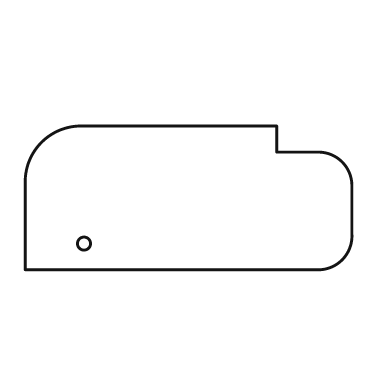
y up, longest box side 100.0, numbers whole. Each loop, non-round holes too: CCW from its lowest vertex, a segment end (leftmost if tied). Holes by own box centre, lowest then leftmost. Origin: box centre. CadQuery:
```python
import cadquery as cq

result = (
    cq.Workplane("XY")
    .moveTo(-50.0, -22.0)
    .lineTo(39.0, -22.0)
    .threePointArc((47.0, -19.0), (50.0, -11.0))
    .lineTo(50.0, 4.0)
    .threePointArc((47.0, 11.0), (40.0, 14.0))
    .lineTo(27.0, 14.0)
    .lineTo(27.0, 22.0)
    .lineTo(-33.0, 22.0)
    .threePointArc((-45.0, 17.0), (-50.0, 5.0))
    .close()
    .moveTo(-32.0, -14.0)
    .circle(2.0)
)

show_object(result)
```